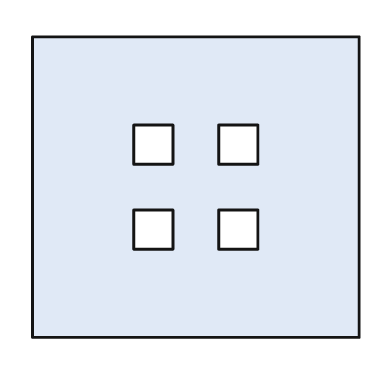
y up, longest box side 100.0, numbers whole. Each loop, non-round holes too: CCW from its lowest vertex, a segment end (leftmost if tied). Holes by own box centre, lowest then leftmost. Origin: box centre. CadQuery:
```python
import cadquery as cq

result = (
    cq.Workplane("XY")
    .moveTo(-50.0, -46.0)
    .lineTo(50.0, -46.0)
    .lineTo(50.0, 46.0)
    .lineTo(-50.0, 46.0)
    .close()
    .moveTo(-19.0, -19.0)
    .lineTo(-7.0, -19.0)
    .lineTo(-7.0, -7.0)
    .lineTo(-19.0, -7.0)
    .close()
    .moveTo(7.0, -19.0)
    .lineTo(19.0, -19.0)
    .lineTo(19.0, -7.0)
    .lineTo(7.0, -7.0)
    .close()
    .moveTo(-19.0, 7.0)
    .lineTo(-7.0, 7.0)
    .lineTo(-7.0, 19.0)
    .lineTo(-19.0, 19.0)
    .close()
    .moveTo(7.0, 7.0)
    .lineTo(19.0, 7.0)
    .lineTo(19.0, 19.0)
    .lineTo(7.0, 19.0)
    .close()
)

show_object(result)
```